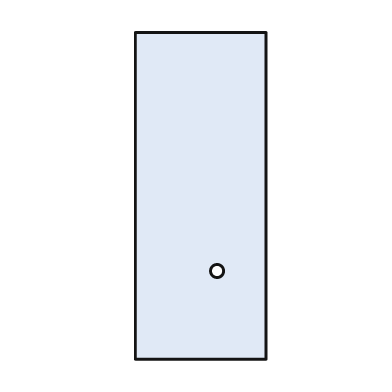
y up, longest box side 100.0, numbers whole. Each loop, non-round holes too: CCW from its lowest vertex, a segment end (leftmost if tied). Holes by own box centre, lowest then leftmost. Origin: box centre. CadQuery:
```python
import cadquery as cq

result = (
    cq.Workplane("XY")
    .moveTo(-20.0, -50.0)
    .lineTo(20.0, -50.0)
    .lineTo(20.0, 50.0)
    .lineTo(-20.0, 50.0)
    .close()
    .moveTo(5.0, -23.0)
    .circle(2.0)
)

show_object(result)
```